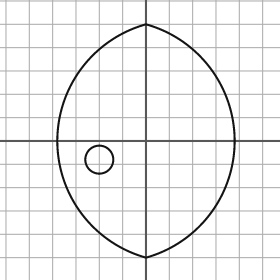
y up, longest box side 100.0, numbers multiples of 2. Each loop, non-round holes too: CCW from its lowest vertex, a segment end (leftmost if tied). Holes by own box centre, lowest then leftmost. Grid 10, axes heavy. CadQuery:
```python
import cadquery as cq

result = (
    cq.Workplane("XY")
    .moveTo(0.0, -50.0)
    .threePointArc((38.0, 0.0), (0.0, 50.0))
    .threePointArc((-38.0, 0.0), (0.0, -50.0))
    .close()
    .moveTo(-20.0, -8.0)
    .circle(6.0)
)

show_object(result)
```